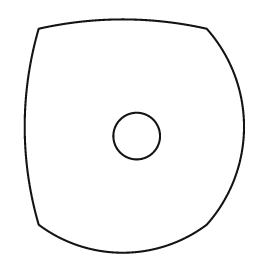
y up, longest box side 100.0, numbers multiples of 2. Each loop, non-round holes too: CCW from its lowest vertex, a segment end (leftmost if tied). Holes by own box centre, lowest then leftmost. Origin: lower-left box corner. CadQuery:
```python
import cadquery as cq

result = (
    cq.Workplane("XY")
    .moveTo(6.0, 12.0)
    .threePointArc((42.0, 0.0), (78.0, 12.0))
    .threePointArc((94.0, 54.0), (78.0, 96.0))
    .threePointArc((42.0, 100.0), (6.0, 96.0))
    .threePointArc((0.0, 54.0), (6.0, 12.0))
    .close()
    .moveTo(48.0, 50.0)
    .circle(10.0)
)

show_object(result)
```